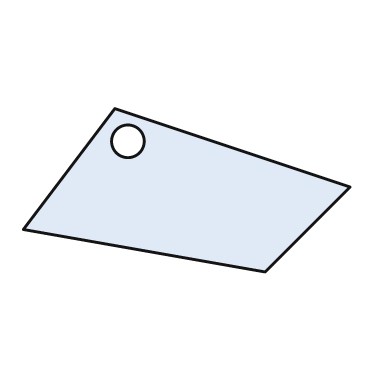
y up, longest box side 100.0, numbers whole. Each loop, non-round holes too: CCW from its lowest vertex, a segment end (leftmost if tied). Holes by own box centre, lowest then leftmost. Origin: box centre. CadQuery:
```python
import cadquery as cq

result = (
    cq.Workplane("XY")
    .moveTo(24.0, -25.0)
    .lineTo(50.0, 1.0)
    .lineTo(-22.0, 25.0)
    .lineTo(-50.0, -12.0)
    .close()
    .moveTo(-18.0, 15.0)
    .circle(5.0)
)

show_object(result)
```